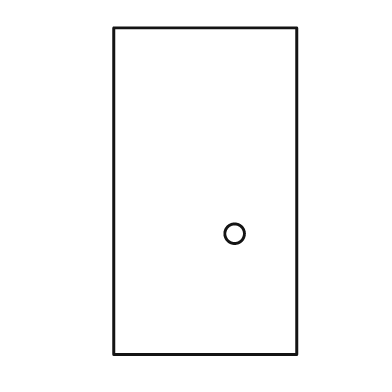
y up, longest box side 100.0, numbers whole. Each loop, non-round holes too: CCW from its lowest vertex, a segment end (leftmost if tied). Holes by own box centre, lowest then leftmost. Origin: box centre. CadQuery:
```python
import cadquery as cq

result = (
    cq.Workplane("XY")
    .moveTo(-28.0, -50.0)
    .lineTo(28.0, -50.0)
    .lineTo(28.0, 50.0)
    .lineTo(-28.0, 50.0)
    .close()
    .moveTo(9.0, -13.0)
    .circle(3.0)
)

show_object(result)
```